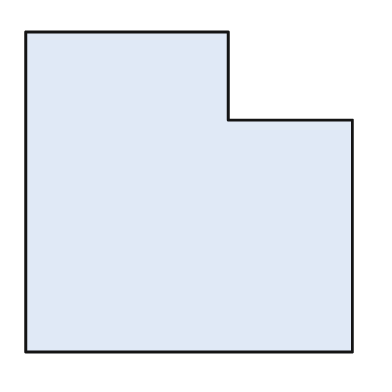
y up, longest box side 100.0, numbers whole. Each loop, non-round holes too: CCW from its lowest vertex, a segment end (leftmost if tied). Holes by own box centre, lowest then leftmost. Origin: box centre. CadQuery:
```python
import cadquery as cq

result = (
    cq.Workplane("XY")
    .moveTo(-50.0, -49.0)
    .lineTo(50.0, -49.0)
    .lineTo(50.0, 22.0)
    .lineTo(12.0, 22.0)
    .lineTo(12.0, 49.0)
    .lineTo(-50.0, 49.0)
    .close()
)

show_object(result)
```